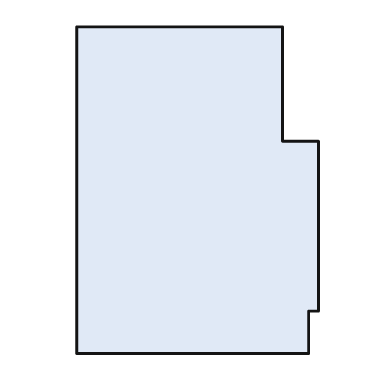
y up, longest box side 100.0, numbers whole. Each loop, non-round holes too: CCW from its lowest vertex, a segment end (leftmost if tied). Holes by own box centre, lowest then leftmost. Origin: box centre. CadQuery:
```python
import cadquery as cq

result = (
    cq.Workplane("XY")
    .moveTo(-37.0, -50.0)
    .lineTo(34.0, -50.0)
    .lineTo(34.0, -37.0)
    .lineTo(37.0, -37.0)
    .lineTo(37.0, 15.0)
    .lineTo(26.0, 15.0)
    .lineTo(26.0, 50.0)
    .lineTo(-37.0, 50.0)
    .close()
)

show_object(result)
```